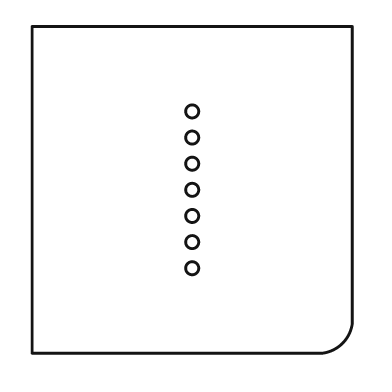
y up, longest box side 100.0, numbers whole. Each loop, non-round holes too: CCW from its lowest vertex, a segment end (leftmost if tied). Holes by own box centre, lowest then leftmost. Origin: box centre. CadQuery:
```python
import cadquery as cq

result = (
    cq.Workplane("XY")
    .moveTo(-49.0, -50.0)
    .lineTo(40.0, -50.0)
    .threePointArc((46.0, -47.0), (49.0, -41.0))
    .lineTo(49.0, 50.0)
    .lineTo(-49.0, 50.0)
    .close()
    .moveTo(0.0, -24.0)
    .circle(2.0)
    .moveTo(0.0, -16.0)
    .circle(2.0)
    .moveTo(0.0, -8.0)
    .circle(2.0)
    .moveTo(0.0, 0.0)
    .circle(2.0)
    .moveTo(0.0, 8.0)
    .circle(2.0)
    .moveTo(0.0, 16.0)
    .circle(2.0)
    .moveTo(0.0, 24.0)
    .circle(2.0)
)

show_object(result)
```